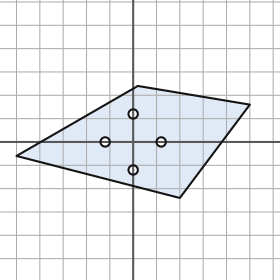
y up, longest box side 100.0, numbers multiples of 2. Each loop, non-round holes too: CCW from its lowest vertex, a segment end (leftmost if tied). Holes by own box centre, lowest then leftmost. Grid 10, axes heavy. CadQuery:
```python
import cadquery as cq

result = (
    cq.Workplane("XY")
    .moveTo(20.0, -24.0)
    .lineTo(50.0, 16.0)
    .lineTo(2.0, 24.0)
    .lineTo(-50.0, -6.0)
    .close()
    .moveTo(0.0, -12.0)
    .circle(2.0)
    .moveTo(-12.0, 0.0)
    .circle(2.0)
    .moveTo(12.0, 0.0)
    .circle(2.0)
    .moveTo(0.0, 12.0)
    .circle(2.0)
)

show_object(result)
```